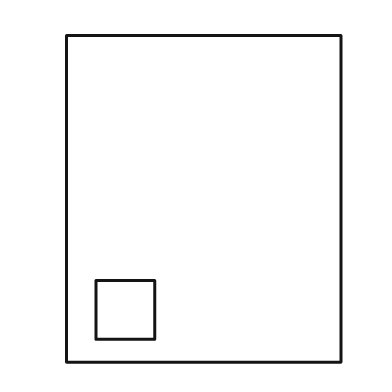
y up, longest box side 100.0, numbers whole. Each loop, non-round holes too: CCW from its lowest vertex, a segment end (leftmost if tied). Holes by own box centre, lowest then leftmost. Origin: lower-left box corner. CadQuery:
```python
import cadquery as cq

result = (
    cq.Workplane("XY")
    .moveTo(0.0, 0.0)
    .lineTo(84.0, 0.0)
    .lineTo(84.0, 100.0)
    .lineTo(0.0, 100.0)
    .close()
    .moveTo(9.0, 7.0)
    .lineTo(27.0, 7.0)
    .lineTo(27.0, 25.0)
    .lineTo(9.0, 25.0)
    .close()
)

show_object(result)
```